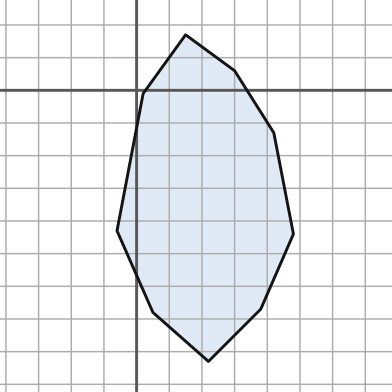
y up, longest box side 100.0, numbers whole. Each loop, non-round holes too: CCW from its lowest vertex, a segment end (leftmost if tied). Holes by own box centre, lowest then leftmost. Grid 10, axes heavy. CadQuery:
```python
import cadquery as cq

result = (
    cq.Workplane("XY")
    .moveTo(22.0, -83.0)
    .lineTo(38.0, -67.0)
    .lineTo(48.0, -44.0)
    .lineTo(42.0, -13.0)
    .lineTo(30.0, 6.0)
    .lineTo(15.0, 17.0)
    .lineTo(2.0, -1.0)
    .lineTo(-6.0, -43.0)
    .lineTo(5.0, -68.0)
    .close()
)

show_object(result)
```